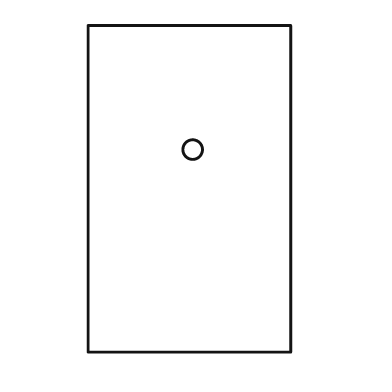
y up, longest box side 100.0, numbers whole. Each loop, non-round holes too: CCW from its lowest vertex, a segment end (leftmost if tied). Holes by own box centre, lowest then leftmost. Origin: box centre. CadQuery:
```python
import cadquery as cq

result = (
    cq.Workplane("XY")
    .moveTo(-31.0, -50.0)
    .lineTo(31.0, -50.0)
    .lineTo(31.0, 50.0)
    .lineTo(-31.0, 50.0)
    .close()
    .moveTo(1.0, 12.0)
    .circle(3.0)
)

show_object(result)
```